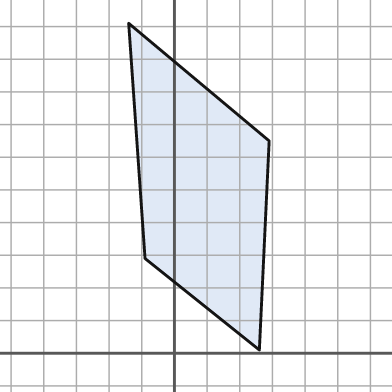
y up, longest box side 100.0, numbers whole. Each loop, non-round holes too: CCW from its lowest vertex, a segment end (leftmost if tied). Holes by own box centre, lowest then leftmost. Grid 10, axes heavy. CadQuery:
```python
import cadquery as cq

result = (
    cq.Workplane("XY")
    .moveTo(26.0, 1.0)
    .lineTo(29.0, 65.0)
    .lineTo(-14.0, 101.0)
    .lineTo(-9.0, 29.0)
    .close()
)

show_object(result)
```